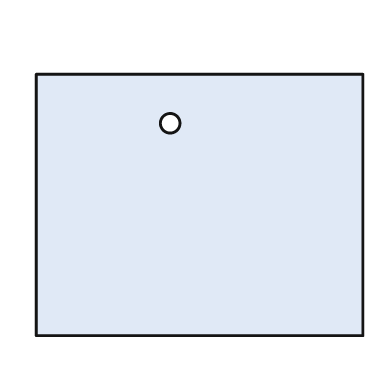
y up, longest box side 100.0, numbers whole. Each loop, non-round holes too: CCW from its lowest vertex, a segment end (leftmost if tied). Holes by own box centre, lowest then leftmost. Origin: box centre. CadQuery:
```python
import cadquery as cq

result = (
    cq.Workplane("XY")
    .moveTo(-50.0, -40.0)
    .lineTo(50.0, -40.0)
    .lineTo(50.0, 40.0)
    .lineTo(-50.0, 40.0)
    .close()
    .moveTo(-9.0, 25.0)
    .circle(3.0)
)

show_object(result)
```